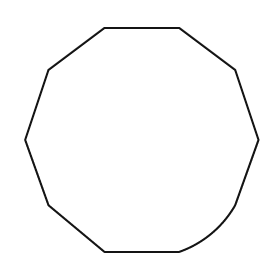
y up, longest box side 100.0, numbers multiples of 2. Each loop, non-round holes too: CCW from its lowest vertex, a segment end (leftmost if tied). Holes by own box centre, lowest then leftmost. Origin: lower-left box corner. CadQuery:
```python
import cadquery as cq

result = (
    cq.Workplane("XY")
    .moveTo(34.0, 0.0)
    .lineTo(66.0, 0.0)
    .threePointArc((80.0, 8.0), (90.0, 20.0))
    .lineTo(100.0, 48.0)
    .lineTo(90.0, 78.0)
    .lineTo(66.0, 96.0)
    .lineTo(34.0, 96.0)
    .lineTo(10.0, 78.0)
    .lineTo(0.0, 48.0)
    .lineTo(10.0, 20.0)
    .close()
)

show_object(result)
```